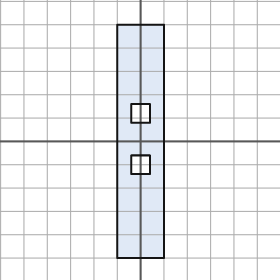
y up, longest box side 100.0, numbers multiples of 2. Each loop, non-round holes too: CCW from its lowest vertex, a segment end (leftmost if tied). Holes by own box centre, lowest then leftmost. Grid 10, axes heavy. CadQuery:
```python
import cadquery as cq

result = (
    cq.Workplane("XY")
    .moveTo(-10.0, -50.0)
    .lineTo(10.0, -50.0)
    .lineTo(10.0, 50.0)
    .lineTo(-10.0, 50.0)
    .close()
    .moveTo(-4.0, -14.0)
    .lineTo(4.0, -14.0)
    .lineTo(4.0, -6.0)
    .lineTo(-4.0, -6.0)
    .close()
    .moveTo(-4.0, 8.0)
    .lineTo(4.0, 8.0)
    .lineTo(4.0, 16.0)
    .lineTo(-4.0, 16.0)
    .close()
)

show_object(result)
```